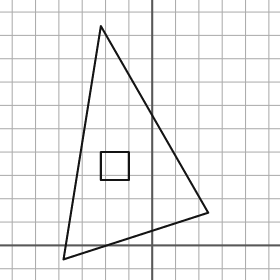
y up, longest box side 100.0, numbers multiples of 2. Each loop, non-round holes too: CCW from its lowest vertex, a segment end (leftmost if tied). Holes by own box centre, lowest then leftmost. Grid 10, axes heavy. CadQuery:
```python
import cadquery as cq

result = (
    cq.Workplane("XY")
    .moveTo(-38.0, -6.0)
    .lineTo(24.0, 14.0)
    .lineTo(-22.0, 94.0)
    .close()
    .moveTo(-22.0, 28.0)
    .lineTo(-10.0, 28.0)
    .lineTo(-10.0, 40.0)
    .lineTo(-22.0, 40.0)
    .close()
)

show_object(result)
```